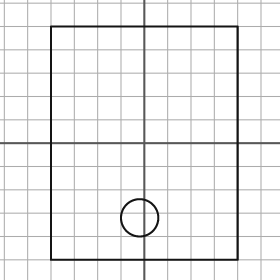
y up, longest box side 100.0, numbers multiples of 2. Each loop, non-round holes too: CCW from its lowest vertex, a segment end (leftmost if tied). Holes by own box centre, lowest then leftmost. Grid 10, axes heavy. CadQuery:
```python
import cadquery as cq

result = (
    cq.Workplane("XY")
    .moveTo(-40.0, -50.0)
    .lineTo(40.0, -50.0)
    .lineTo(40.0, 50.0)
    .lineTo(-40.0, 50.0)
    .close()
    .moveTo(-2.0, -32.0)
    .circle(8.0)
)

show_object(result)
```